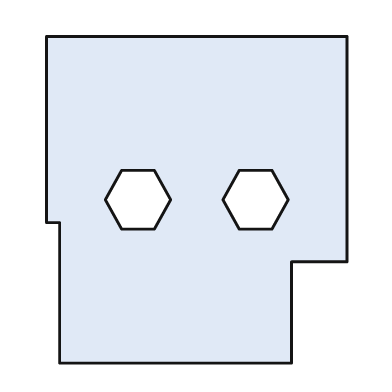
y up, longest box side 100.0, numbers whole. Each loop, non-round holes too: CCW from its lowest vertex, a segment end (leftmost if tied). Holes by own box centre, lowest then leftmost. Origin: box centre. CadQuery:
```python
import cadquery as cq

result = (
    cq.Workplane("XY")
    .moveTo(-42.0, -50.0)
    .lineTo(29.0, -50.0)
    .lineTo(29.0, -19.0)
    .lineTo(46.0, -19.0)
    .lineTo(46.0, 50.0)
    .lineTo(-46.0, 50.0)
    .lineTo(-46.0, -7.0)
    .lineTo(-42.0, -7.0)
    .close()
    .moveTo(-23.0, -9.0)
    .lineTo(-13.0, -9.0)
    .lineTo(-8.0, 0.0)
    .lineTo(-13.0, 9.0)
    .lineTo(-23.0, 9.0)
    .lineTo(-28.0, 0.0)
    .close()
    .moveTo(13.0, -9.0)
    .lineTo(23.0, -9.0)
    .lineTo(28.0, 0.0)
    .lineTo(23.0, 9.0)
    .lineTo(13.0, 9.0)
    .lineTo(8.0, 0.0)
    .close()
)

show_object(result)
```